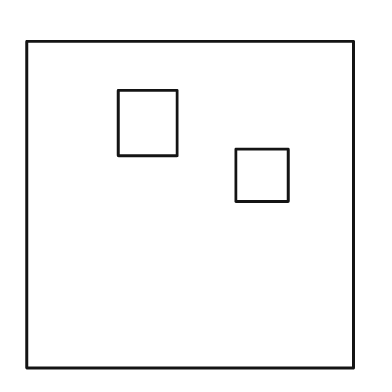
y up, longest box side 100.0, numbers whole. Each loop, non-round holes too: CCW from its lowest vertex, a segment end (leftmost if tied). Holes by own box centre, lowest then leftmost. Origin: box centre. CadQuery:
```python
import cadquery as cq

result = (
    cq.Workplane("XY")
    .moveTo(-50.0, -50.0)
    .lineTo(50.0, -50.0)
    .lineTo(50.0, 50.0)
    .lineTo(-50.0, 50.0)
    .close()
    .moveTo(14.0, 1.0)
    .lineTo(30.0, 1.0)
    .lineTo(30.0, 17.0)
    .lineTo(14.0, 17.0)
    .close()
    .moveTo(-22.0, 15.0)
    .lineTo(-4.0, 15.0)
    .lineTo(-4.0, 35.0)
    .lineTo(-22.0, 35.0)
    .close()
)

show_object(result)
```